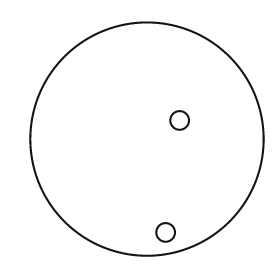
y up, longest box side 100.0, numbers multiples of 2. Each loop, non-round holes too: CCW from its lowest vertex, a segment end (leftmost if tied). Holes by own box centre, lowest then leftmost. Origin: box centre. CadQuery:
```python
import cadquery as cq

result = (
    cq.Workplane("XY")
    .moveTo(0.0, 0.0)
    .circle(50.0)
    .moveTo(8.0, -40.0)
    .circle(4.0)
    .moveTo(14.0, 8.0)
    .circle(4.0)
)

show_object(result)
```